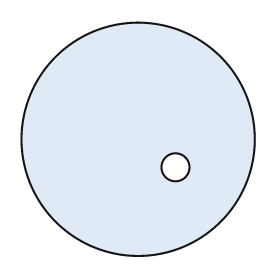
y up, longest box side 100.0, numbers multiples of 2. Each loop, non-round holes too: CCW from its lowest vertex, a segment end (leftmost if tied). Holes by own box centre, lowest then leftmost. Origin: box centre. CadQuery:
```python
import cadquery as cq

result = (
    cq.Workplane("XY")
    .moveTo(0.0, 0.0)
    .circle(50.0)
    .moveTo(16.0, -12.0)
    .circle(6.0)
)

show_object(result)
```